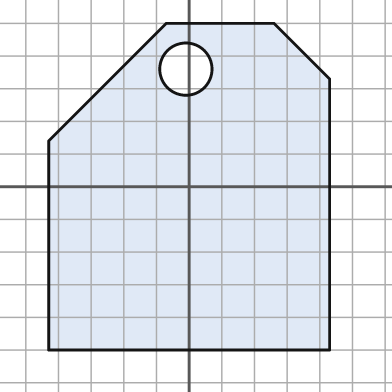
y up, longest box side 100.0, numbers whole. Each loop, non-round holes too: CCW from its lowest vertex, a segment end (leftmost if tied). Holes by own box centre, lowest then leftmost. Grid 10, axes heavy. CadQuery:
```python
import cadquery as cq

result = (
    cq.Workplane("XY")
    .moveTo(-43.0, -50.0)
    .lineTo(43.0, -50.0)
    .lineTo(43.0, 33.0)
    .lineTo(26.0, 50.0)
    .lineTo(-7.0, 50.0)
    .lineTo(-43.0, 14.0)
    .close()
    .moveTo(-1.0, 36.0)
    .circle(8.0)
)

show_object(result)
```